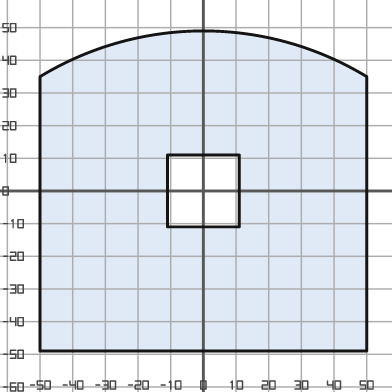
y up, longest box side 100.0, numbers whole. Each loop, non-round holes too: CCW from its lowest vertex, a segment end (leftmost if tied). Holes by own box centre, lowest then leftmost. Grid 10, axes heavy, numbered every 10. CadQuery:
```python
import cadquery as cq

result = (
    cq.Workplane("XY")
    .moveTo(-50.0, -49.0)
    .lineTo(50.0, -49.0)
    .lineTo(50.0, 35.0)
    .threePointArc((0.0, 49.0), (-50.0, 35.0))
    .close()
    .moveTo(-11.0, -11.0)
    .lineTo(11.0, -11.0)
    .lineTo(11.0, 11.0)
    .lineTo(-11.0, 11.0)
    .close()
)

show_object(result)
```